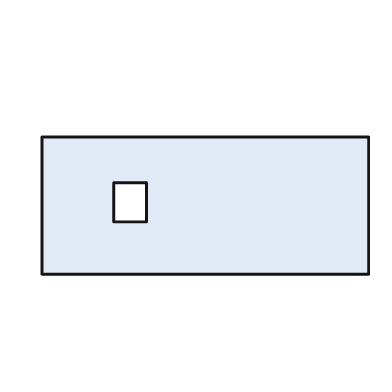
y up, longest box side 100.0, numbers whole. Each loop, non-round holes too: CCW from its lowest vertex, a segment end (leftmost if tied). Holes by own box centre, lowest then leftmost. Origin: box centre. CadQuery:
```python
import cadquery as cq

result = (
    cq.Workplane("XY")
    .moveTo(-50.0, -21.0)
    .lineTo(50.0, -21.0)
    .lineTo(50.0, 21.0)
    .lineTo(-50.0, 21.0)
    .close()
    .moveTo(-28.0, -5.0)
    .lineTo(-18.0, -5.0)
    .lineTo(-18.0, 7.0)
    .lineTo(-28.0, 7.0)
    .close()
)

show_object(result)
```